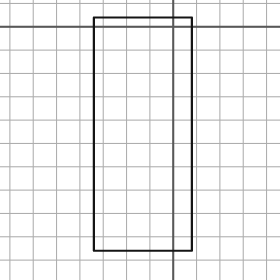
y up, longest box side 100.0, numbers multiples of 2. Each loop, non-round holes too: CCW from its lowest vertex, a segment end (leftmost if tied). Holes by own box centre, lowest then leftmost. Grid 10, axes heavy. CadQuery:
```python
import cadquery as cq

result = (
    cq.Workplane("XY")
    .moveTo(-34.0, -96.0)
    .lineTo(8.0, -96.0)
    .lineTo(8.0, 4.0)
    .lineTo(-34.0, 4.0)
    .close()
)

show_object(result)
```